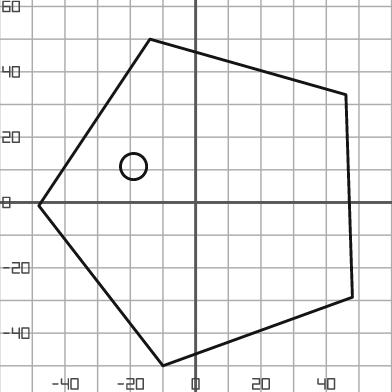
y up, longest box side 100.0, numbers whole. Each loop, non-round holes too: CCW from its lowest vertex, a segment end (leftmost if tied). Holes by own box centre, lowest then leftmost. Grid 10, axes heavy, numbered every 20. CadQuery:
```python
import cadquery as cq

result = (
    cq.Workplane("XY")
    .moveTo(-10.0, -50.0)
    .lineTo(48.0, -29.0)
    .lineTo(46.0, 33.0)
    .lineTo(-14.0, 50.0)
    .lineTo(-48.0, -1.0)
    .close()
    .moveTo(-19.0, 11.0)
    .circle(4.0)
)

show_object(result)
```